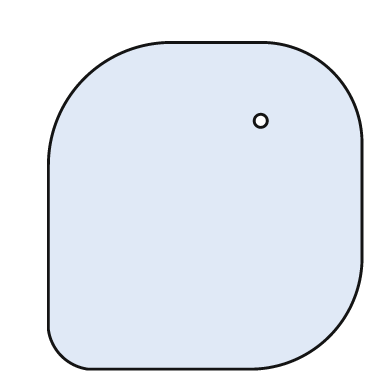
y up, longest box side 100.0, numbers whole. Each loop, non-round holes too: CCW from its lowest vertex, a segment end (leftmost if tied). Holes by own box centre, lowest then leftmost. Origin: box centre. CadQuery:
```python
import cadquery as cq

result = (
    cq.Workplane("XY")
    .moveTo(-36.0, -50.0)
    .lineTo(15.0, -50.0)
    .threePointArc((38.0, -40.0), (48.0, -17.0))
    .lineTo(48.0, 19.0)
    .threePointArc((39.0, 41.0), (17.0, 50.0))
    .lineTo(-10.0, 50.0)
    .threePointArc((-37.0, 39.0), (-48.0, 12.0))
    .lineTo(-48.0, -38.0)
    .threePointArc((-44.0, -46.0), (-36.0, -50.0))
    .close()
    .moveTo(17.0, 26.0)
    .circle(2.0)
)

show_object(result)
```